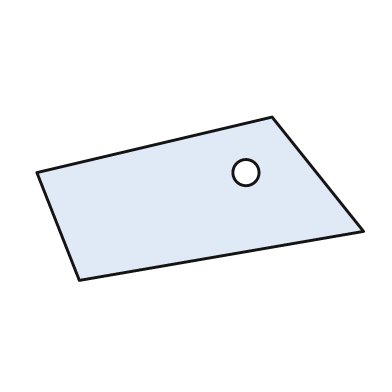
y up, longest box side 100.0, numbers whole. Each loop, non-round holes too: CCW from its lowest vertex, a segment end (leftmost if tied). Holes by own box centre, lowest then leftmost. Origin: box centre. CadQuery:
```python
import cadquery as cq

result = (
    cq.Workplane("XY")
    .moveTo(-37.0, -25.0)
    .lineTo(50.0, -10.0)
    .lineTo(22.0, 25.0)
    .lineTo(-50.0, 8.0)
    .close()
    .moveTo(14.0, 8.0)
    .circle(4.0)
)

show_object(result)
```